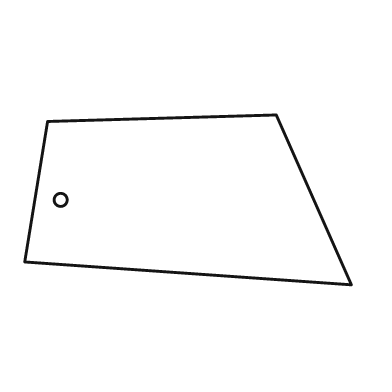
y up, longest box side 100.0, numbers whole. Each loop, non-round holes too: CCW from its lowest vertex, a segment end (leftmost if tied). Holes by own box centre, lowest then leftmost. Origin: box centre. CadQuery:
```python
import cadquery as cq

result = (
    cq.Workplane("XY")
    .moveTo(50.0, -26.0)
    .lineTo(27.0, 26.0)
    .lineTo(-43.0, 24.0)
    .lineTo(-50.0, -19.0)
    .close()
    .moveTo(-39.0, 0.0)
    .circle(2.0)
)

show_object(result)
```